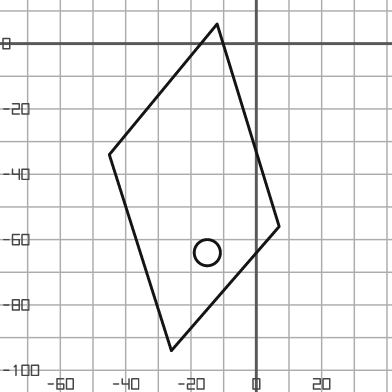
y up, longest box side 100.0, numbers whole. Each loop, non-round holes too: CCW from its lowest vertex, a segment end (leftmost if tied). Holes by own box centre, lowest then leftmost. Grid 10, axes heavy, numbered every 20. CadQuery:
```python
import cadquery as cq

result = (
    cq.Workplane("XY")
    .moveTo(-26.0, -94.0)
    .lineTo(7.0, -56.0)
    .lineTo(-12.0, 6.0)
    .lineTo(-45.0, -34.0)
    .close()
    .moveTo(-15.0, -64.0)
    .circle(4.0)
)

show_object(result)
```